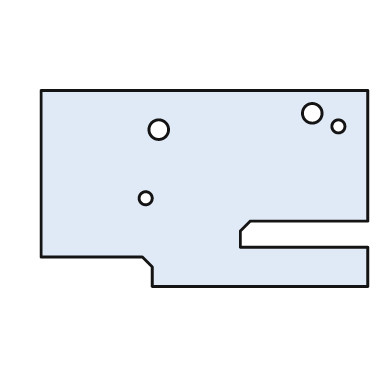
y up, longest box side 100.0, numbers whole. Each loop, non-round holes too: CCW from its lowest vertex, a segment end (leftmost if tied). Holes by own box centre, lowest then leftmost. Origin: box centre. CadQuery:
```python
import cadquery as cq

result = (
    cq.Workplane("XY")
    .moveTo(-16.0, -30.0)
    .lineTo(50.0, -30.0)
    .lineTo(50.0, -18.0)
    .lineTo(11.0, -18.0)
    .lineTo(11.0, -13.0)
    .lineTo(14.0, -10.0)
    .lineTo(50.0, -10.0)
    .lineTo(50.0, 30.0)
    .lineTo(-50.0, 30.0)
    .lineTo(-50.0, -21.0)
    .lineTo(-19.0, -21.0)
    .lineTo(-16.0, -24.0)
    .close()
    .moveTo(-18.0, -3.0)
    .circle(2.0)
    .moveTo(-14.0, 18.0)
    .circle(3.0)
    .moveTo(41.0, 19.0)
    .circle(2.0)
    .moveTo(33.0, 23.0)
    .circle(3.0)
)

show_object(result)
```